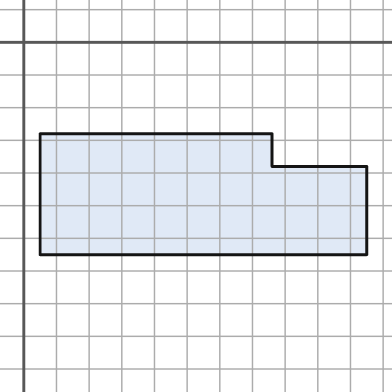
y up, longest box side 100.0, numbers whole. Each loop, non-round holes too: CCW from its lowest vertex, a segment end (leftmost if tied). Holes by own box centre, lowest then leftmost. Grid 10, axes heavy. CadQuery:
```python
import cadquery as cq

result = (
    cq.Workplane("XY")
    .moveTo(5.0, -65.0)
    .lineTo(105.0, -65.0)
    .lineTo(105.0, -38.0)
    .lineTo(76.0, -38.0)
    .lineTo(76.0, -28.0)
    .lineTo(5.0, -28.0)
    .close()
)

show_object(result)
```